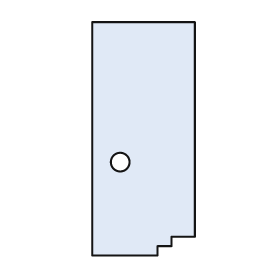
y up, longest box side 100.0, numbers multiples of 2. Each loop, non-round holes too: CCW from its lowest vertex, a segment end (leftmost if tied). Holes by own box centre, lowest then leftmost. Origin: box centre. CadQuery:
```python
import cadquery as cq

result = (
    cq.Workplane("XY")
    .moveTo(-22.0, -50.0)
    .lineTo(6.0, -50.0)
    .lineTo(6.0, -46.0)
    .lineTo(12.0, -46.0)
    .lineTo(12.0, -42.0)
    .lineTo(22.0, -42.0)
    .lineTo(22.0, 50.0)
    .lineTo(-22.0, 50.0)
    .close()
    .moveTo(-10.0, -10.0)
    .circle(4.0)
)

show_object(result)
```